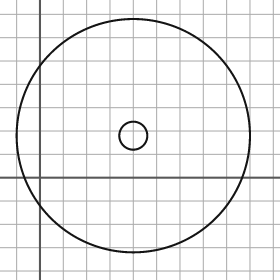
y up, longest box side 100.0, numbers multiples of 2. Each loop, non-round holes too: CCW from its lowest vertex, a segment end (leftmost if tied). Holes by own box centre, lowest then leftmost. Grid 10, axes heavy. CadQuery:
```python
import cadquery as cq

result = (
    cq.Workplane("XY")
    .moveTo(40.0, 18.0)
    .circle(50.0)
    .moveTo(40.0, 18.0)
    .circle(6.0)
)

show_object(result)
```